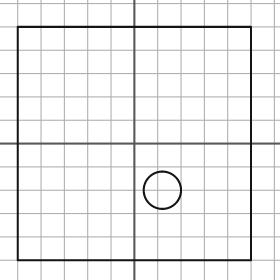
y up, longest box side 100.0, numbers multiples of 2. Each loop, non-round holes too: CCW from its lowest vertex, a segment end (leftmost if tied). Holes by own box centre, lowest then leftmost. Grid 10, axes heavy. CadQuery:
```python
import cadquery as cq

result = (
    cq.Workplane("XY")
    .moveTo(-50.0, -50.0)
    .lineTo(50.0, -50.0)
    .lineTo(50.0, 50.0)
    .lineTo(-50.0, 50.0)
    .close()
    .moveTo(12.0, -20.0)
    .circle(8.0)
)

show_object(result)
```